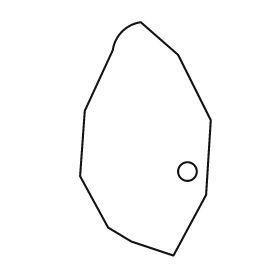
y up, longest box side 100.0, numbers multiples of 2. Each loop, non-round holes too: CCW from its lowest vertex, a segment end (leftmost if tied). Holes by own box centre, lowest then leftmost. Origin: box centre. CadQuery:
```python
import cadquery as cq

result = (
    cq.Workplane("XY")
    .moveTo(12.0, -50.0)
    .lineTo(26.0, -24.0)
    .lineTo(28.0, 8.0)
    .lineTo(14.0, 36.0)
    .lineTo(-2.0, 50.0)
    .threePointArc((-10.0, 46.0), (-14.0, 38.0))
    .lineTo(-26.0, 12.0)
    .lineTo(-28.0, -16.0)
    .lineTo(-16.0, -38.0)
    .lineTo(-6.0, -44.0)
    .close()
    .moveTo(18.0, -14.0)
    .circle(4.0)
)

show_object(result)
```